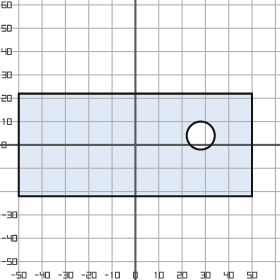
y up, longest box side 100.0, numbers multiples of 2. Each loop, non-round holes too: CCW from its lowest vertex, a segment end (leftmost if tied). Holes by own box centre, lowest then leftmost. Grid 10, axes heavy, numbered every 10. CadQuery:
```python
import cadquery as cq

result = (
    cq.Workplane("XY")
    .moveTo(-50.0, -22.0)
    .lineTo(50.0, -22.0)
    .lineTo(50.0, 22.0)
    .lineTo(-50.0, 22.0)
    .close()
    .moveTo(28.0, 4.0)
    .circle(6.0)
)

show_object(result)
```